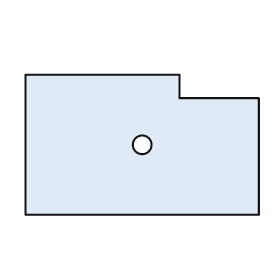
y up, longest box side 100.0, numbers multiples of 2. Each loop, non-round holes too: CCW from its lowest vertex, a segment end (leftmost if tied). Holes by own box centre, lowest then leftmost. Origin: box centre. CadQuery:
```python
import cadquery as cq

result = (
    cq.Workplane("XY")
    .moveTo(-50.0, -30.0)
    .lineTo(50.0, -30.0)
    .lineTo(50.0, 20.0)
    .lineTo(16.0, 20.0)
    .lineTo(16.0, 30.0)
    .lineTo(-50.0, 30.0)
    .close()
    .moveTo(0.0, 0.0)
    .circle(4.0)
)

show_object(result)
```